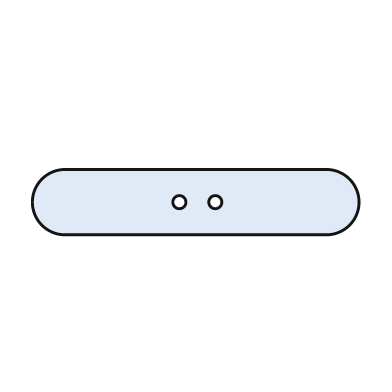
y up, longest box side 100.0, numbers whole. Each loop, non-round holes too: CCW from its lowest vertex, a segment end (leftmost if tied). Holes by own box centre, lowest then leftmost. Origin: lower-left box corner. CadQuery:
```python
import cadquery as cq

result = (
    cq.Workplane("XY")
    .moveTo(10.0, 0.0)
    .lineTo(90.0, 0.0)
    .threePointArc((100.0, 10.0), (90.0, 20.0))
    .lineTo(10.0, 20.0)
    .threePointArc((0.0, 10.0), (10.0, 0.0))
    .close()
    .moveTo(45.0, 10.0)
    .circle(2.0)
    .moveTo(56.0, 10.0)
    .circle(2.0)
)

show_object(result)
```